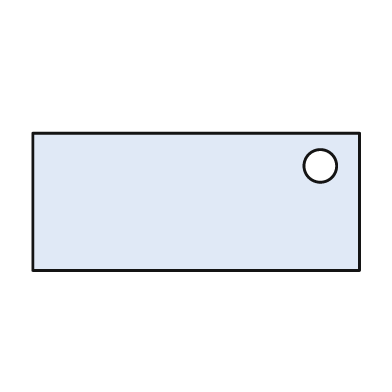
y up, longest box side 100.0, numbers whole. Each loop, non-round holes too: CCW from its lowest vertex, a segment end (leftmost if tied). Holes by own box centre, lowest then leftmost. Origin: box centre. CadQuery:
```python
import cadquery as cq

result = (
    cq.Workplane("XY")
    .moveTo(-50.0, -21.0)
    .lineTo(50.0, -21.0)
    .lineTo(50.0, 21.0)
    .lineTo(-50.0, 21.0)
    .close()
    .moveTo(38.0, 11.0)
    .circle(5.0)
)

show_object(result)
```